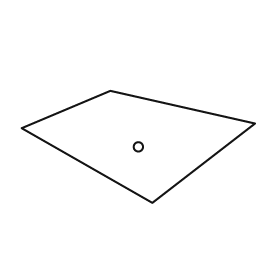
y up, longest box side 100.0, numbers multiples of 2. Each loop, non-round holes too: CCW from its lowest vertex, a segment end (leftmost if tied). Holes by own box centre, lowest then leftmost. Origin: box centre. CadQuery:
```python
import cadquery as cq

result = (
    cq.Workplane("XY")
    .moveTo(6.0, -24.0)
    .lineTo(50.0, 10.0)
    .lineTo(-12.0, 24.0)
    .lineTo(-50.0, 8.0)
    .close()
    .moveTo(0.0, 0.0)
    .circle(2.0)
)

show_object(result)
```